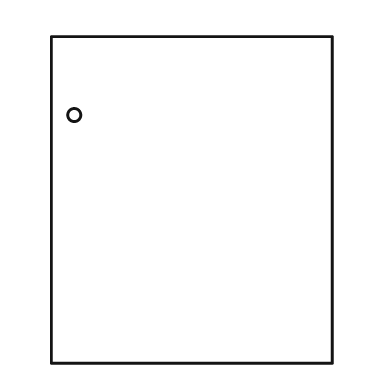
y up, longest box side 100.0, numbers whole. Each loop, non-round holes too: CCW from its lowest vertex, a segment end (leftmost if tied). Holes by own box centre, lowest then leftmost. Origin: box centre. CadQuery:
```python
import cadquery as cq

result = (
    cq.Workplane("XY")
    .moveTo(-43.0, -50.0)
    .lineTo(43.0, -50.0)
    .lineTo(43.0, 50.0)
    .lineTo(-43.0, 50.0)
    .close()
    .moveTo(-36.0, 26.0)
    .circle(2.0)
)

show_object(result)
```